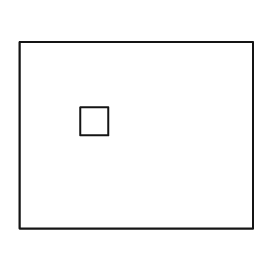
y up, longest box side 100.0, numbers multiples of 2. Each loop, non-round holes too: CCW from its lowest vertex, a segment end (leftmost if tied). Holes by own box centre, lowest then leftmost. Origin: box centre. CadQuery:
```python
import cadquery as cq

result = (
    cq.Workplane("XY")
    .moveTo(-50.0, -40.0)
    .lineTo(50.0, -40.0)
    .lineTo(50.0, 40.0)
    .lineTo(-50.0, 40.0)
    .close()
    .moveTo(-24.0, 0.0)
    .lineTo(-12.0, 0.0)
    .lineTo(-12.0, 12.0)
    .lineTo(-24.0, 12.0)
    .close()
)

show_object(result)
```